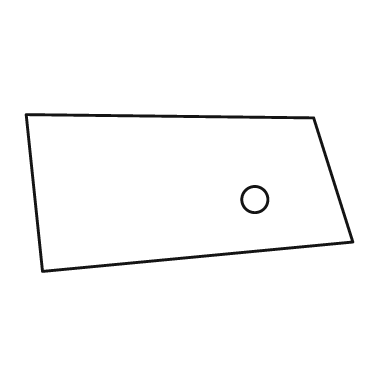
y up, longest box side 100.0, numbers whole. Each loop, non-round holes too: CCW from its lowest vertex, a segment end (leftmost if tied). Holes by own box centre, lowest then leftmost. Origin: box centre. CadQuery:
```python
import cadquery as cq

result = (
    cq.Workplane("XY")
    .moveTo(-45.0, -24.0)
    .lineTo(50.0, -15.0)
    .lineTo(38.0, 23.0)
    .lineTo(-50.0, 24.0)
    .close()
    .moveTo(20.0, -2.0)
    .circle(4.0)
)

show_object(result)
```